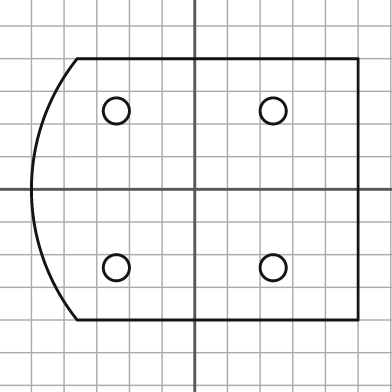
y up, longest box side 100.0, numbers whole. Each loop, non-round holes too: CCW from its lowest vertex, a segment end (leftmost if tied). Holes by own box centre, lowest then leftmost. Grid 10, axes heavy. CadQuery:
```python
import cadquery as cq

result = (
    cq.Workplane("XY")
    .moveTo(-36.0, -40.0)
    .lineTo(50.0, -40.0)
    .lineTo(50.0, 40.0)
    .lineTo(-36.0, 40.0)
    .threePointArc((-50.0, 0.0), (-36.0, -40.0))
    .close()
    .moveTo(-24.0, -24.0)
    .circle(4.0)
    .moveTo(24.0, -24.0)
    .circle(4.0)
    .moveTo(-24.0, 24.0)
    .circle(4.0)
    .moveTo(24.0, 24.0)
    .circle(4.0)
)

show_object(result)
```